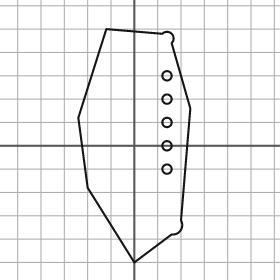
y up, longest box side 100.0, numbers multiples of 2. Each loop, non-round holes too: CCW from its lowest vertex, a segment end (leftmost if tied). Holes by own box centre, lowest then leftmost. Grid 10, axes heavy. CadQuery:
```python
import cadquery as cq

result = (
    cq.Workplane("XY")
    .moveTo(0.0, -50.0)
    .lineTo(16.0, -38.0)
    .threePointArc((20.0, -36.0), (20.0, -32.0))
    .lineTo(24.0, 16.0)
    .lineTo(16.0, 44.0)
    .threePointArc((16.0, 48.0), (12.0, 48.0))
    .lineTo(-12.0, 50.0)
    .lineTo(-24.0, 12.0)
    .lineTo(-20.0, -18.0)
    .close()
    .moveTo(14.0, -10.0)
    .circle(2.0)
    .moveTo(14.0, 0.0)
    .circle(2.0)
    .moveTo(14.0, 10.0)
    .circle(2.0)
    .moveTo(14.0, 20.0)
    .circle(2.0)
    .moveTo(14.0, 30.0)
    .circle(2.0)
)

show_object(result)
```